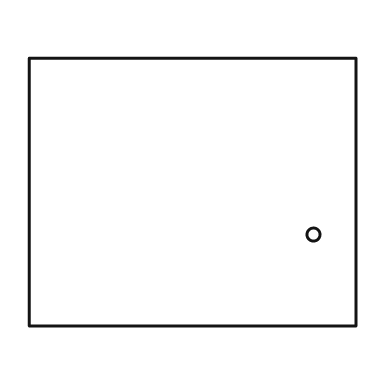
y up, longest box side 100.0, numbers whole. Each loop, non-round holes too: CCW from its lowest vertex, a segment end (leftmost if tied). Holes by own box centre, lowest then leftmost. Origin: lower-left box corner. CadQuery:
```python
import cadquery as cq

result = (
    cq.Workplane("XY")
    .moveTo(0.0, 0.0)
    .lineTo(100.0, 0.0)
    .lineTo(100.0, 82.0)
    .lineTo(0.0, 82.0)
    .close()
    .moveTo(87.0, 28.0)
    .circle(2.0)
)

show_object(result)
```